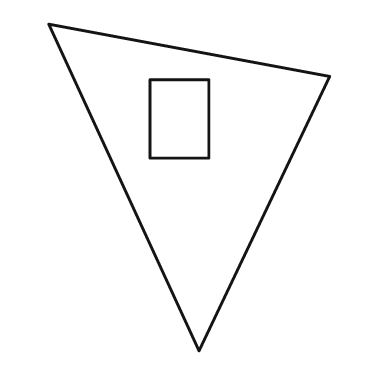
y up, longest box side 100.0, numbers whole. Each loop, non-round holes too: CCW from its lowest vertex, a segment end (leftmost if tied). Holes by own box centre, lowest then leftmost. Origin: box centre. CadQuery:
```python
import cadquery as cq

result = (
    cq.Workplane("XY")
    .moveTo(3.0, -50.0)
    .lineTo(43.0, 34.0)
    .lineTo(-43.0, 50.0)
    .close()
    .moveTo(-12.0, 9.0)
    .lineTo(6.0, 9.0)
    .lineTo(6.0, 33.0)
    .lineTo(-12.0, 33.0)
    .close()
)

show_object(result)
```